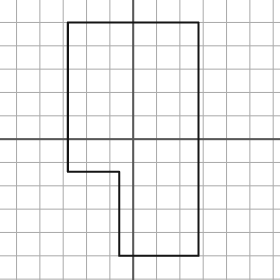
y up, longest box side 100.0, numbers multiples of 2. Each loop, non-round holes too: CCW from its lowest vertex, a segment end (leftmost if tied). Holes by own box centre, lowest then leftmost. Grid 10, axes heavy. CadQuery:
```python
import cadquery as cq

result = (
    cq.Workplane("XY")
    .moveTo(-6.0, -50.0)
    .lineTo(28.0, -50.0)
    .lineTo(28.0, 50.0)
    .lineTo(-28.0, 50.0)
    .lineTo(-28.0, -14.0)
    .lineTo(-6.0, -14.0)
    .close()
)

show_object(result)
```